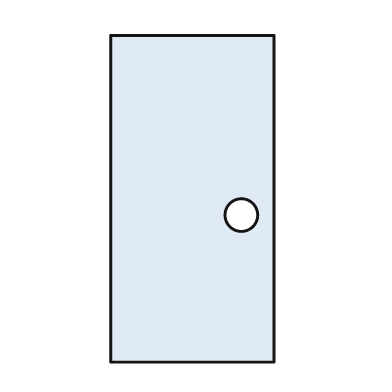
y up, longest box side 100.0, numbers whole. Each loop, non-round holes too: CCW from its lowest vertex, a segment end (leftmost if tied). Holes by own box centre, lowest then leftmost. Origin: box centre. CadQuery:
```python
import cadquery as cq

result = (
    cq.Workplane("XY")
    .moveTo(-25.0, -50.0)
    .lineTo(25.0, -50.0)
    .lineTo(25.0, 50.0)
    .lineTo(-25.0, 50.0)
    .close()
    .moveTo(15.0, -5.0)
    .circle(5.0)
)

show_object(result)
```